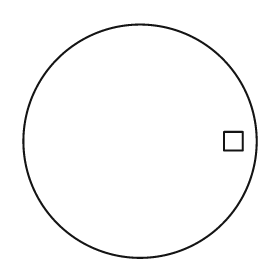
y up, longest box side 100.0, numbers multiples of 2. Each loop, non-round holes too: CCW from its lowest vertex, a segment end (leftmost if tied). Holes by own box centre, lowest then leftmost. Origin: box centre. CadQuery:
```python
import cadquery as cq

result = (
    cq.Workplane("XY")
    .moveTo(0.0, 0.0)
    .circle(50.0)
    .moveTo(36.0, -4.0)
    .lineTo(44.0, -4.0)
    .lineTo(44.0, 4.0)
    .lineTo(36.0, 4.0)
    .close()
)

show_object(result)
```